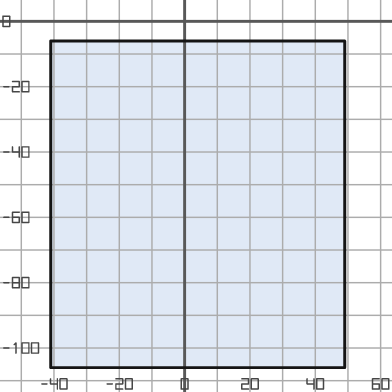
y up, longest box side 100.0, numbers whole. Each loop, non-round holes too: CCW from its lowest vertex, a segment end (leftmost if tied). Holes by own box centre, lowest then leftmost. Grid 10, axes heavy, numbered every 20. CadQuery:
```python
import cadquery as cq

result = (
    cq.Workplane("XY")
    .moveTo(-41.0, -106.0)
    .lineTo(49.0, -106.0)
    .lineTo(49.0, -6.0)
    .lineTo(-41.0, -6.0)
    .close()
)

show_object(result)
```